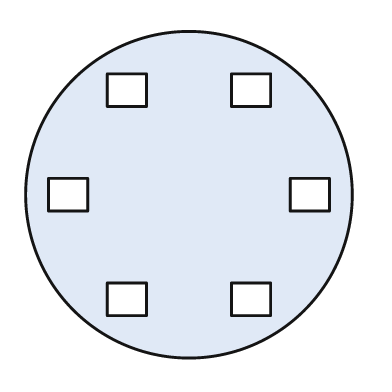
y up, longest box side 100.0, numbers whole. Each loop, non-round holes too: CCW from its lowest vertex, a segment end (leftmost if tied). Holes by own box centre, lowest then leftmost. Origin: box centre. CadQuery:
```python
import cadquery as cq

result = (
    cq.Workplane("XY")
    .moveTo(0.0, 0.0)
    .circle(50.0)
    .moveTo(-25.0, -37.0)
    .lineTo(-13.0, -37.0)
    .lineTo(-13.0, -27.0)
    .lineTo(-25.0, -27.0)
    .close()
    .moveTo(13.0, -37.0)
    .lineTo(25.0, -37.0)
    .lineTo(25.0, -27.0)
    .lineTo(13.0, -27.0)
    .close()
    .moveTo(-43.0, -5.0)
    .lineTo(-31.0, -5.0)
    .lineTo(-31.0, 5.0)
    .lineTo(-43.0, 5.0)
    .close()
    .moveTo(31.0, -5.0)
    .lineTo(43.0, -5.0)
    .lineTo(43.0, 5.0)
    .lineTo(31.0, 5.0)
    .close()
    .moveTo(-25.0, 27.0)
    .lineTo(-13.0, 27.0)
    .lineTo(-13.0, 37.0)
    .lineTo(-25.0, 37.0)
    .close()
    .moveTo(13.0, 27.0)
    .lineTo(25.0, 27.0)
    .lineTo(25.0, 37.0)
    .lineTo(13.0, 37.0)
    .close()
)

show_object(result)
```